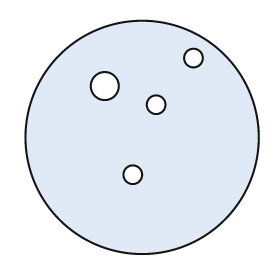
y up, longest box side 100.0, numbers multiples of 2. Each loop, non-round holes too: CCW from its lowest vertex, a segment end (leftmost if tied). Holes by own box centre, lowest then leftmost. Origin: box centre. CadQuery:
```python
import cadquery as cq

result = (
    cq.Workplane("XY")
    .moveTo(0.0, 0.0)
    .circle(50.0)
    .moveTo(-4.0, -16.0)
    .circle(4.0)
    .moveTo(6.0, 14.0)
    .circle(4.0)
    .moveTo(-16.0, 22.0)
    .circle(6.0)
    .moveTo(22.0, 34.0)
    .circle(4.0)
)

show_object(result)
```